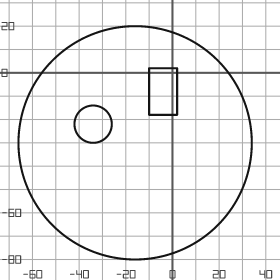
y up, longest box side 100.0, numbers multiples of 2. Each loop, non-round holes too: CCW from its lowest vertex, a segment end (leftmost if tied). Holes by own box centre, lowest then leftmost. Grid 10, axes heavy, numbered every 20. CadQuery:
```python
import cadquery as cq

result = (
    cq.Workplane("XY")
    .moveTo(-16.0, -30.0)
    .circle(50.0)
    .moveTo(-34.0, -22.0)
    .circle(8.0)
    .moveTo(-10.0, -18.0)
    .lineTo(2.0, -18.0)
    .lineTo(2.0, 2.0)
    .lineTo(-10.0, 2.0)
    .close()
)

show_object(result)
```